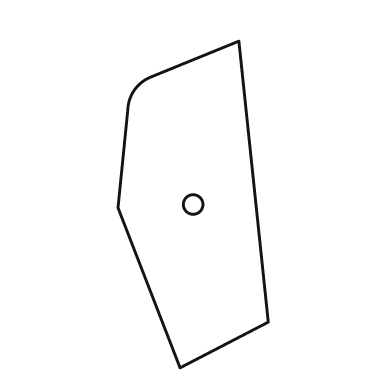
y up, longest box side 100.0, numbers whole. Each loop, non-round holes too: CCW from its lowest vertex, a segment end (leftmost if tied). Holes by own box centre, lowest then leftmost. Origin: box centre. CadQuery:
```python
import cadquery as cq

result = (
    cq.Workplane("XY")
    .moveTo(-4.0, -50.0)
    .lineTo(23.0, -36.0)
    .lineTo(14.0, 50.0)
    .lineTo(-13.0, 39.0)
    .threePointArc((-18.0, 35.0), (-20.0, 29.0))
    .lineTo(-23.0, -1.0)
    .close()
    .moveTo(0.0, 0.0)
    .circle(3.0)
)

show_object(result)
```